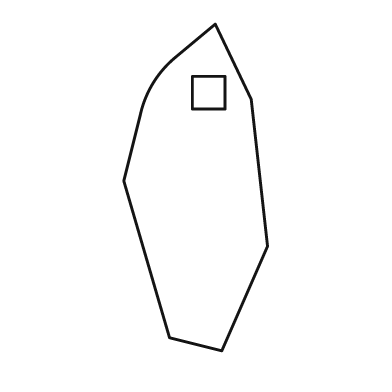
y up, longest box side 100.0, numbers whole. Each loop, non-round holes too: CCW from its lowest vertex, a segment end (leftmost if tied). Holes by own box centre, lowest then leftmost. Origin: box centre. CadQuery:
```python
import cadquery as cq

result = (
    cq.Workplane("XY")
    .moveTo(8.0, -50.0)
    .lineTo(22.0, -18.0)
    .lineTo(17.0, 27.0)
    .lineTo(6.0, 50.0)
    .lineTo(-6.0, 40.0)
    .threePointArc((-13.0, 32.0), (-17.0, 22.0))
    .lineTo(-22.0, 2.0)
    .lineTo(-8.0, -46.0)
    .close()
    .moveTo(-1.0, 24.0)
    .lineTo(9.0, 24.0)
    .lineTo(9.0, 34.0)
    .lineTo(-1.0, 34.0)
    .close()
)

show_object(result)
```